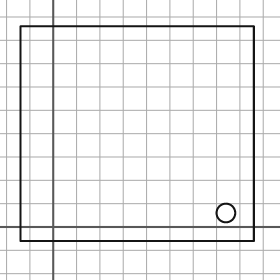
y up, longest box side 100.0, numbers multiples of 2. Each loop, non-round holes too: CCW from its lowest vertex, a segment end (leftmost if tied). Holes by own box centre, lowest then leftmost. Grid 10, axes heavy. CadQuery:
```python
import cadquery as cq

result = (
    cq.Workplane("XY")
    .moveTo(-14.0, -6.0)
    .lineTo(86.0, -6.0)
    .lineTo(86.0, 86.0)
    .lineTo(-14.0, 86.0)
    .close()
    .moveTo(74.0, 6.0)
    .circle(4.0)
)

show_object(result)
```